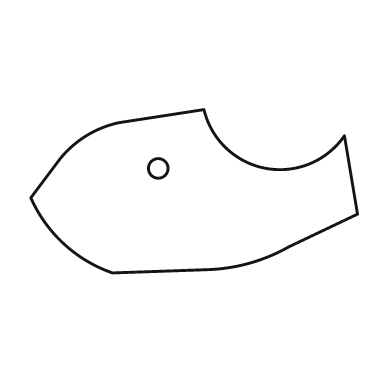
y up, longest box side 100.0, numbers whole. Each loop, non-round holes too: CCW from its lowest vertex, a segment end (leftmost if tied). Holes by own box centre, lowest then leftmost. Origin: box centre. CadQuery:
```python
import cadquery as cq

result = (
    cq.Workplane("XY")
    .moveTo(-25.0, -25.0)
    .lineTo(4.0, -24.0)
    .threePointArc((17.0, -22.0), (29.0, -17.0))
    .lineTo(50.0, -7.0)
    .lineTo(46.0, 17.0)
    .threePointArc((22.0, 7.0), (3.0, 25.0))
    .lineTo(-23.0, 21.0)
    .threePointArc((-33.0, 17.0), (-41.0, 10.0))
    .lineTo(-50.0, -2.0)
    .threePointArc((-40.0, -16.0), (-25.0, -25.0))
    .close()
    .moveTo(-11.0, 7.0)
    .circle(3.0)
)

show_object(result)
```